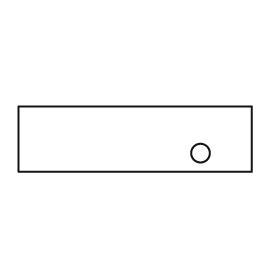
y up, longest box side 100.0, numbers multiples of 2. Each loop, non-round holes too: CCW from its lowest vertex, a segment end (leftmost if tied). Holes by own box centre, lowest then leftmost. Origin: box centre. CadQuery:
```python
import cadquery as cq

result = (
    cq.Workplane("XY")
    .moveTo(-50.0, -14.0)
    .lineTo(50.0, -14.0)
    .lineTo(50.0, 14.0)
    .lineTo(-50.0, 14.0)
    .close()
    .moveTo(28.0, -6.0)
    .circle(4.0)
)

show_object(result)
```